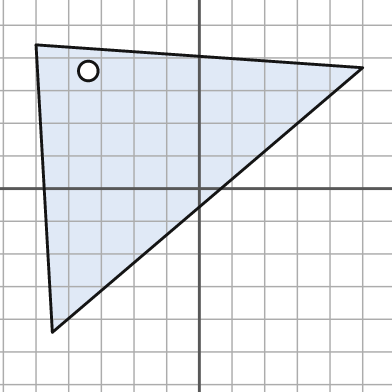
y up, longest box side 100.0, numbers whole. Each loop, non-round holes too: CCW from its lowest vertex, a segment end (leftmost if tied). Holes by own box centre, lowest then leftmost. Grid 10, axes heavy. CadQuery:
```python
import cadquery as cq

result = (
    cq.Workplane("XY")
    .moveTo(-45.0, -44.0)
    .lineTo(50.0, 37.0)
    .lineTo(-50.0, 44.0)
    .close()
    .moveTo(-34.0, 36.0)
    .circle(3.0)
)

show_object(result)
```